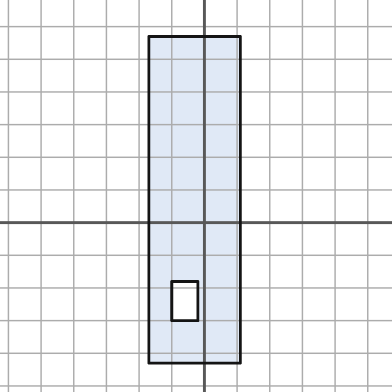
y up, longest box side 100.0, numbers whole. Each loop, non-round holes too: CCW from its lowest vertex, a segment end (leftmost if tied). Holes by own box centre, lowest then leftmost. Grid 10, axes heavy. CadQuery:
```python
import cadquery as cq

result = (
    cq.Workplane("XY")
    .moveTo(-17.0, -43.0)
    .lineTo(11.0, -43.0)
    .lineTo(11.0, 57.0)
    .lineTo(-17.0, 57.0)
    .close()
    .moveTo(-10.0, -30.0)
    .lineTo(-2.0, -30.0)
    .lineTo(-2.0, -18.0)
    .lineTo(-10.0, -18.0)
    .close()
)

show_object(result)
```